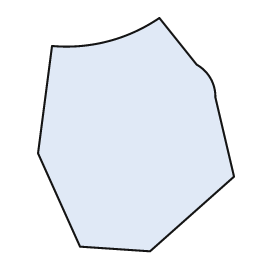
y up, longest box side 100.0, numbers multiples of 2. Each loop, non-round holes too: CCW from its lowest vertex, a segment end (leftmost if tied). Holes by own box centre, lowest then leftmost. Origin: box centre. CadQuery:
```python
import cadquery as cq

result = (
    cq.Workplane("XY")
    .moveTo(6.0, -50.0)
    .lineTo(42.0, -18.0)
    .lineTo(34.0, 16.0)
    .threePointArc((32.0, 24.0), (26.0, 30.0))
    .lineTo(10.0, 50.0)
    .threePointArc((-12.0, 40.0), (-36.0, 38.0))
    .lineTo(-42.0, -8.0)
    .lineTo(-24.0, -48.0)
    .close()
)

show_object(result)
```